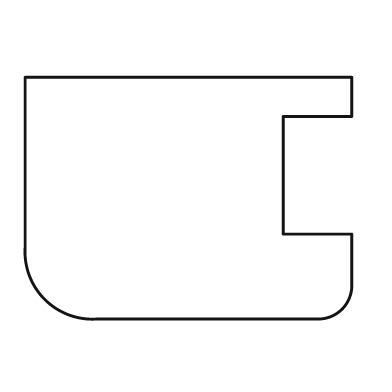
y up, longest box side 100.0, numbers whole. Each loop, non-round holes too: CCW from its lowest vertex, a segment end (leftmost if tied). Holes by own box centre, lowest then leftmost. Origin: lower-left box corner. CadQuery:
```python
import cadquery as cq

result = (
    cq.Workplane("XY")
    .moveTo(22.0, 0.0)
    .lineTo(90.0, 0.0)
    .threePointArc((97.0, 3.0), (100.0, 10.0))
    .lineTo(100.0, 26.0)
    .lineTo(79.0, 26.0)
    .lineTo(79.0, 62.0)
    .lineTo(100.0, 62.0)
    .lineTo(100.0, 74.0)
    .lineTo(0.0, 74.0)
    .lineTo(0.0, 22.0)
    .threePointArc((6.0, 6.0), (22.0, 0.0))
    .close()
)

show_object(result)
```